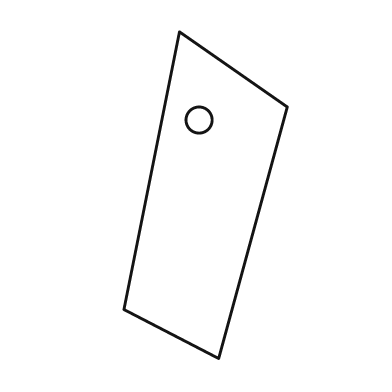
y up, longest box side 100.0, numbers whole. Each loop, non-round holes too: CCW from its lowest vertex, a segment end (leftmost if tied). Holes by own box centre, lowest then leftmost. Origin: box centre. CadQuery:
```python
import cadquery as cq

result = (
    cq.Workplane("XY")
    .moveTo(4.0, -50.0)
    .lineTo(25.0, 27.0)
    .lineTo(-8.0, 50.0)
    .lineTo(-25.0, -35.0)
    .close()
    .moveTo(-2.0, 23.0)
    .circle(4.0)
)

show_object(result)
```